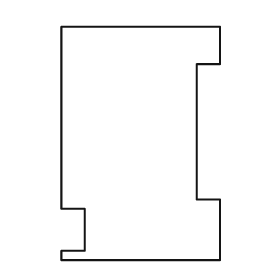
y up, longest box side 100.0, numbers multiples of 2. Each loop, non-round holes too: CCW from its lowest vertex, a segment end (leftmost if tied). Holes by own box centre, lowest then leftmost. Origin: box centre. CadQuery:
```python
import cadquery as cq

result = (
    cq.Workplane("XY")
    .moveTo(-34.0, -50.0)
    .lineTo(34.0, -50.0)
    .lineTo(34.0, -24.0)
    .lineTo(24.0, -24.0)
    .lineTo(24.0, 34.0)
    .lineTo(34.0, 34.0)
    .lineTo(34.0, 50.0)
    .lineTo(-34.0, 50.0)
    .lineTo(-34.0, -28.0)
    .lineTo(-24.0, -28.0)
    .lineTo(-24.0, -46.0)
    .lineTo(-34.0, -46.0)
    .close()
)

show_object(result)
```